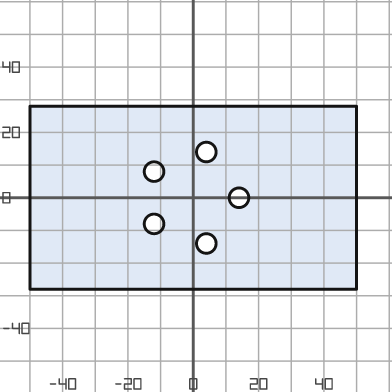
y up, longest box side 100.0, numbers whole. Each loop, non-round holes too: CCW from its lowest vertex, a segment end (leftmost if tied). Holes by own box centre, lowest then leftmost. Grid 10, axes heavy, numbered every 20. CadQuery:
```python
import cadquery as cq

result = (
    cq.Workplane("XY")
    .moveTo(-50.0, -28.0)
    .lineTo(50.0, -28.0)
    .lineTo(50.0, 28.0)
    .lineTo(-50.0, 28.0)
    .close()
    .moveTo(4.0, -14.0)
    .circle(3.0)
    .moveTo(-12.0, -8.0)
    .circle(3.0)
    .moveTo(14.0, 0.0)
    .circle(3.0)
    .moveTo(-12.0, 8.0)
    .circle(3.0)
    .moveTo(4.0, 14.0)
    .circle(3.0)
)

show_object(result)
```